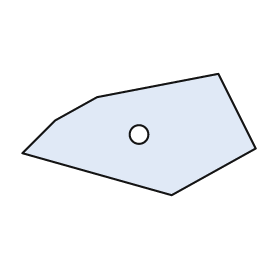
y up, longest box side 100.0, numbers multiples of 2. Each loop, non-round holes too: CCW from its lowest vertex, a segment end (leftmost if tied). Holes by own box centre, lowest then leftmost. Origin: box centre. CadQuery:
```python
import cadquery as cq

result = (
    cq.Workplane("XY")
    .moveTo(14.0, -26.0)
    .lineTo(50.0, -6.0)
    .lineTo(34.0, 26.0)
    .lineTo(-18.0, 16.0)
    .lineTo(-36.0, 6.0)
    .lineTo(-50.0, -8.0)
    .close()
    .moveTo(0.0, 0.0)
    .circle(4.0)
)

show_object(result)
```